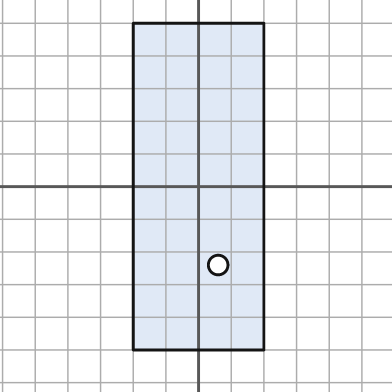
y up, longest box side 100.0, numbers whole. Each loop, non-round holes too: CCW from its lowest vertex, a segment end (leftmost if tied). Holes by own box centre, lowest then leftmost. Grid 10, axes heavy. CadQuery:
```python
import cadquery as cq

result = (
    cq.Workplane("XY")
    .moveTo(-20.0, -50.0)
    .lineTo(20.0, -50.0)
    .lineTo(20.0, 50.0)
    .lineTo(-20.0, 50.0)
    .close()
    .moveTo(6.0, -24.0)
    .circle(3.0)
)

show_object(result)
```